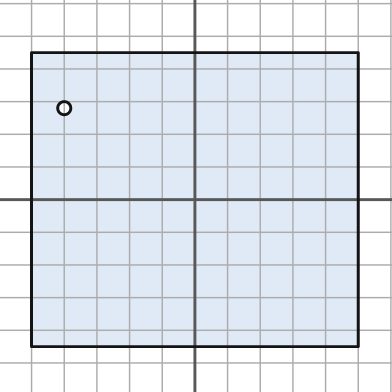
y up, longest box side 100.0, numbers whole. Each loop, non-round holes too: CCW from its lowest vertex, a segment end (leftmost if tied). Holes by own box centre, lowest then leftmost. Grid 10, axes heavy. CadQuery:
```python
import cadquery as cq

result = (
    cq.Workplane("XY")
    .moveTo(-50.0, -45.0)
    .lineTo(50.0, -45.0)
    .lineTo(50.0, 45.0)
    .lineTo(-50.0, 45.0)
    .close()
    .moveTo(-40.0, 28.0)
    .circle(2.0)
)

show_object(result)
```